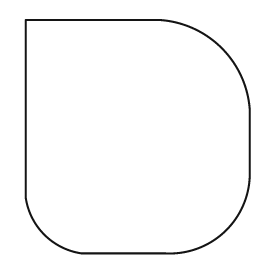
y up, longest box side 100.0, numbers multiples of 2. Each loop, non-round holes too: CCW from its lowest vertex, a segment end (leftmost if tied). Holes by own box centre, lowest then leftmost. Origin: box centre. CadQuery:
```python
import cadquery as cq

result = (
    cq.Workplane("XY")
    .moveTo(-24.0, -50.0)
    .lineTo(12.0, -50.0)
    .threePointArc((38.0, -40.0), (48.0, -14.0))
    .lineTo(48.0, 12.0)
    .threePointArc((36.0, 38.0), (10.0, 50.0))
    .lineTo(-48.0, 50.0)
    .lineTo(-48.0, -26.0)
    .threePointArc((-40.0, -42.0), (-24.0, -50.0))
    .close()
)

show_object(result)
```